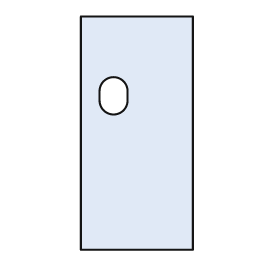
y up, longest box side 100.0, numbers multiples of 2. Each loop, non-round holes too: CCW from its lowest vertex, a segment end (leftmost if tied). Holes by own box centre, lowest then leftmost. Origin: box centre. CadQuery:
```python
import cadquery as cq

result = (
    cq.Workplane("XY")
    .moveTo(-24.0, -50.0)
    .lineTo(24.0, -50.0)
    .lineTo(24.0, 50.0)
    .lineTo(-24.0, 50.0)
    .close()
    .moveTo(-16.0, 14.0)
    .threePointArc((-10.0, 8.0), (-4.0, 14.0))
    .lineTo(-4.0, 18.0)
    .threePointArc((-10.0, 24.0), (-16.0, 18.0))
    .close()
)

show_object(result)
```